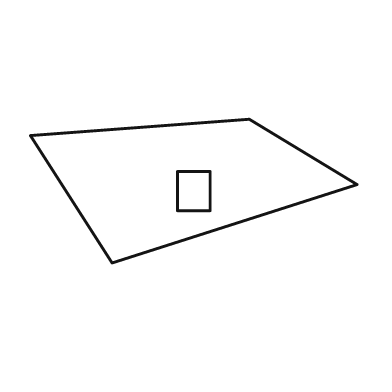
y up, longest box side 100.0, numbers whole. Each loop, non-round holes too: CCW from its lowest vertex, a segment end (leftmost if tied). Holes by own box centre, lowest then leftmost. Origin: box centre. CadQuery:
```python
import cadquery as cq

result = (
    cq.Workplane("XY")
    .moveTo(-25.0, -22.0)
    .lineTo(50.0, 2.0)
    .lineTo(17.0, 22.0)
    .lineTo(-50.0, 17.0)
    .close()
    .moveTo(-5.0, -6.0)
    .lineTo(5.0, -6.0)
    .lineTo(5.0, 6.0)
    .lineTo(-5.0, 6.0)
    .close()
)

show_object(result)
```